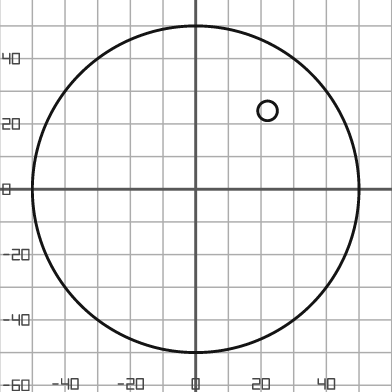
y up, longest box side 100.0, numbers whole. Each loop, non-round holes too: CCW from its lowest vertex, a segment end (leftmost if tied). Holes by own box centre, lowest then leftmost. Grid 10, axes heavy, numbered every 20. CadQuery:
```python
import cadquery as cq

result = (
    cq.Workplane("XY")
    .moveTo(0.0, 0.0)
    .circle(50.0)
    .moveTo(22.0, 24.0)
    .circle(3.0)
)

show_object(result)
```